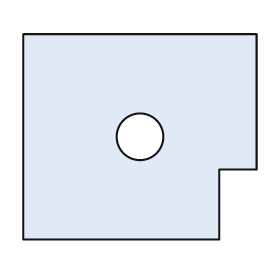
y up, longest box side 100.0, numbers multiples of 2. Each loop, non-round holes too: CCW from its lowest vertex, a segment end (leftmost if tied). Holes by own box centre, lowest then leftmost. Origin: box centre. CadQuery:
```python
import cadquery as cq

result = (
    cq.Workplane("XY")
    .moveTo(-50.0, -44.0)
    .lineTo(34.0, -44.0)
    .lineTo(34.0, -14.0)
    .lineTo(50.0, -14.0)
    .lineTo(50.0, 44.0)
    .lineTo(-50.0, 44.0)
    .close()
    .moveTo(0.0, 0.0)
    .circle(10.0)
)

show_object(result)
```